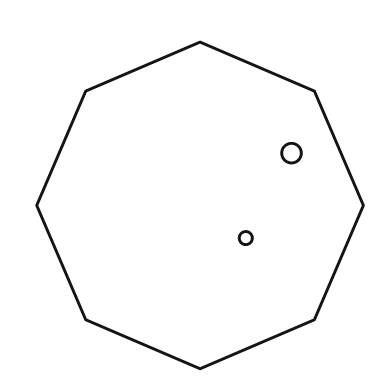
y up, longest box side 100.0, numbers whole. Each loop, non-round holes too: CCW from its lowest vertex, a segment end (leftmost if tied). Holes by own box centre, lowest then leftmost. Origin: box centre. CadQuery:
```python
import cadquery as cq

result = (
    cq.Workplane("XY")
    .moveTo(0.0, -50.0)
    .lineTo(35.0, -35.0)
    .lineTo(50.0, 0.0)
    .lineTo(35.0, 35.0)
    .lineTo(0.0, 50.0)
    .lineTo(-35.0, 35.0)
    .lineTo(-50.0, 0.0)
    .lineTo(-35.0, -35.0)
    .close()
    .moveTo(14.0, -10.0)
    .circle(2.0)
    .moveTo(28.0, 16.0)
    .circle(3.0)
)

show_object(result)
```